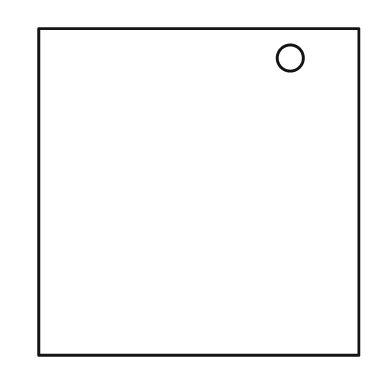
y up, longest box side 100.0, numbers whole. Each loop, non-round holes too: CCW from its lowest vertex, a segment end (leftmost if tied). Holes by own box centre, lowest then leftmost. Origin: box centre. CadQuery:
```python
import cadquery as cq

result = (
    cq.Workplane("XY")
    .moveTo(-49.0, -50.0)
    .lineTo(49.0, -50.0)
    .lineTo(49.0, 50.0)
    .lineTo(-49.0, 50.0)
    .close()
    .moveTo(28.0, 41.0)
    .circle(4.0)
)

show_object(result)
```